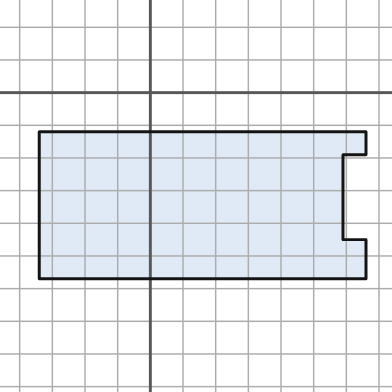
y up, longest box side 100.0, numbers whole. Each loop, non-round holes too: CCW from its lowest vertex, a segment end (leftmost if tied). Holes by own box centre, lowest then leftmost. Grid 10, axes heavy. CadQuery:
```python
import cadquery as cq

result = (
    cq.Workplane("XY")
    .moveTo(-34.0, -57.0)
    .lineTo(66.0, -57.0)
    .lineTo(66.0, -45.0)
    .lineTo(59.0, -45.0)
    .lineTo(59.0, -19.0)
    .lineTo(66.0, -19.0)
    .lineTo(66.0, -12.0)
    .lineTo(-34.0, -12.0)
    .close()
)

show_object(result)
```